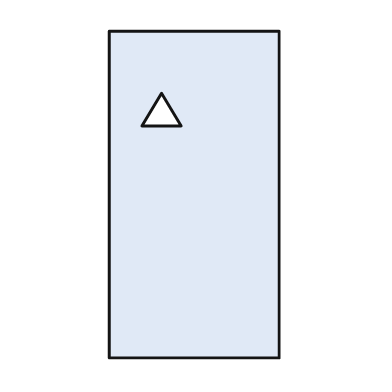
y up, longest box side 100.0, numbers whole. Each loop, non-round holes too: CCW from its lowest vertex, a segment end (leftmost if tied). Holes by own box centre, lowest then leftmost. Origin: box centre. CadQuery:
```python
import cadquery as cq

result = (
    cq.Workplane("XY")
    .moveTo(-26.0, -50.0)
    .lineTo(26.0, -50.0)
    .lineTo(26.0, 50.0)
    .lineTo(-26.0, 50.0)
    .close()
    .moveTo(-16.0, 21.0)
    .lineTo(-4.0, 21.0)
    .lineTo(-10.0, 31.0)
    .close()
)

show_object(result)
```